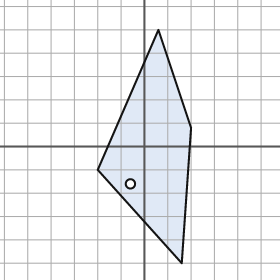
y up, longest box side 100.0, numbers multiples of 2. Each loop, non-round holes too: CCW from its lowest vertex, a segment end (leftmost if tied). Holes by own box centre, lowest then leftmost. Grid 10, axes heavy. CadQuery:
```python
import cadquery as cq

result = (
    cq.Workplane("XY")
    .moveTo(16.0, -50.0)
    .lineTo(20.0, 8.0)
    .lineTo(6.0, 50.0)
    .lineTo(-20.0, -10.0)
    .close()
    .moveTo(-6.0, -16.0)
    .circle(2.0)
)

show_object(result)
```